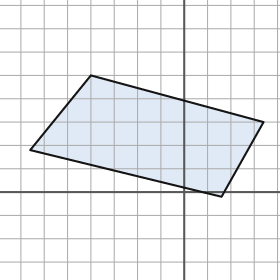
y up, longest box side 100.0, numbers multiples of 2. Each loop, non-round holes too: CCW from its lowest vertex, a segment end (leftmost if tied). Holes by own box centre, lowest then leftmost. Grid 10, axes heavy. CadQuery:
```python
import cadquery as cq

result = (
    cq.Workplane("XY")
    .moveTo(16.0, -2.0)
    .lineTo(34.0, 30.0)
    .lineTo(-40.0, 50.0)
    .lineTo(-66.0, 18.0)
    .close()
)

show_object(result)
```